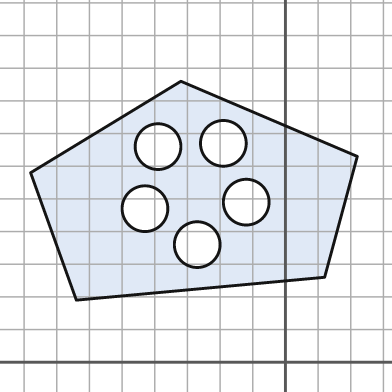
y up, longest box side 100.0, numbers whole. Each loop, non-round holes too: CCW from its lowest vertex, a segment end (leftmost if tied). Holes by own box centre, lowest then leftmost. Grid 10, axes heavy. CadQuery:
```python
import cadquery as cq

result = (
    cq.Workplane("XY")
    .moveTo(-64.0, 19.0)
    .lineTo(12.0, 26.0)
    .lineTo(22.0, 63.0)
    .lineTo(-32.0, 86.0)
    .lineTo(-78.0, 58.0)
    .close()
    .moveTo(-27.0, 36.0)
    .circle(7.0)
    .moveTo(-43.0, 47.0)
    .circle(7.0)
    .moveTo(-12.0, 49.0)
    .circle(7.0)
    .moveTo(-39.0, 66.0)
    .circle(7.0)
    .moveTo(-19.0, 67.0)
    .circle(7.0)
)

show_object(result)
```